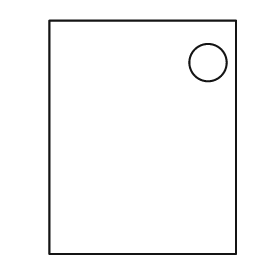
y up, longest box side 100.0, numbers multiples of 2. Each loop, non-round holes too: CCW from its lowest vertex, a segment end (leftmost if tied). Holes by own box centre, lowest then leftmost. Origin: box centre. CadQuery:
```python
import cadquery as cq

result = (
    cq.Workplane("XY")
    .moveTo(-40.0, -50.0)
    .lineTo(40.0, -50.0)
    .lineTo(40.0, 50.0)
    .lineTo(-40.0, 50.0)
    .close()
    .moveTo(28.0, 32.0)
    .circle(8.0)
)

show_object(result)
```